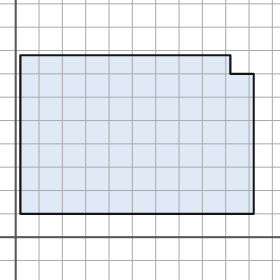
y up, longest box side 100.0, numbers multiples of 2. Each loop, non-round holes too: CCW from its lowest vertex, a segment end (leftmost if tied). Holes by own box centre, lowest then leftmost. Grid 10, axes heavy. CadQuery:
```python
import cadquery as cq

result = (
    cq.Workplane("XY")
    .moveTo(2.0, 10.0)
    .lineTo(102.0, 10.0)
    .lineTo(102.0, 70.0)
    .lineTo(92.0, 70.0)
    .lineTo(92.0, 78.0)
    .lineTo(2.0, 78.0)
    .close()
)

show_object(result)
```